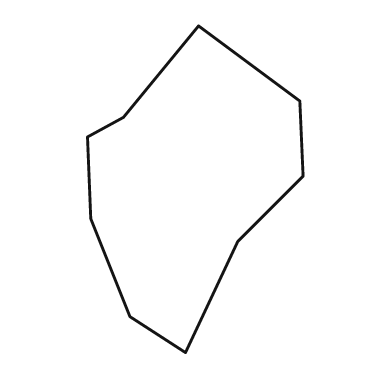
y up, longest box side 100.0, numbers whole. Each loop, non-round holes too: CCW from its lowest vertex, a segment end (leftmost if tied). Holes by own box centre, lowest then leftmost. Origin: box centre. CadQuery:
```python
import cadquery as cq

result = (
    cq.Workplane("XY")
    .moveTo(-3.0, -50.0)
    .lineTo(13.0, -16.0)
    .lineTo(33.0, 4.0)
    .lineTo(32.0, 27.0)
    .lineTo(1.0, 50.0)
    .lineTo(-22.0, 22.0)
    .lineTo(-33.0, 16.0)
    .lineTo(-32.0, -9.0)
    .lineTo(-20.0, -39.0)
    .close()
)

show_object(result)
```